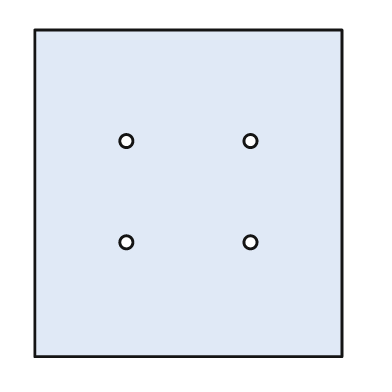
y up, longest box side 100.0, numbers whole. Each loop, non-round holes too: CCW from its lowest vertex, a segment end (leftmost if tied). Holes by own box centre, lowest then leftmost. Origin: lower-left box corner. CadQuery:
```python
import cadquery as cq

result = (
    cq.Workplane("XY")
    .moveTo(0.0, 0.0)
    .lineTo(94.0, 0.0)
    .lineTo(94.0, 100.0)
    .lineTo(0.0, 100.0)
    .close()
    .moveTo(28.0, 35.0)
    .circle(2.0)
    .moveTo(66.0, 35.0)
    .circle(2.0)
    .moveTo(28.0, 66.0)
    .circle(2.0)
    .moveTo(66.0, 66.0)
    .circle(2.0)
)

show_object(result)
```